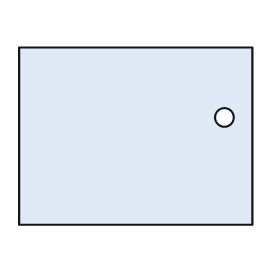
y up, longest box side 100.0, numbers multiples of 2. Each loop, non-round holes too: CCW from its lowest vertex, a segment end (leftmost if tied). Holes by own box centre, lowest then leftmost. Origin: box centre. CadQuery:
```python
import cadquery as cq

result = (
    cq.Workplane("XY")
    .moveTo(-50.0, -38.0)
    .lineTo(50.0, -38.0)
    .lineTo(50.0, 38.0)
    .lineTo(-50.0, 38.0)
    .close()
    .moveTo(38.0, 8.0)
    .circle(4.0)
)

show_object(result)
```